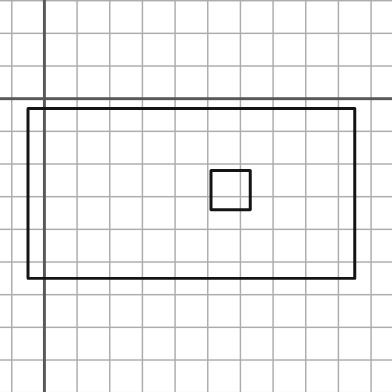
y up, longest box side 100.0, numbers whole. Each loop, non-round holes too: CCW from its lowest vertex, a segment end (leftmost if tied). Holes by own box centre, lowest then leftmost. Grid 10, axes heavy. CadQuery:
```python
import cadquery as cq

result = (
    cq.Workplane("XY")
    .moveTo(-5.0, -55.0)
    .lineTo(95.0, -55.0)
    .lineTo(95.0, -3.0)
    .lineTo(-5.0, -3.0)
    .close()
    .moveTo(51.0, -34.0)
    .lineTo(63.0, -34.0)
    .lineTo(63.0, -22.0)
    .lineTo(51.0, -22.0)
    .close()
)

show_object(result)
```